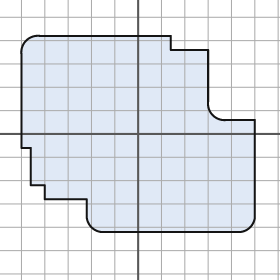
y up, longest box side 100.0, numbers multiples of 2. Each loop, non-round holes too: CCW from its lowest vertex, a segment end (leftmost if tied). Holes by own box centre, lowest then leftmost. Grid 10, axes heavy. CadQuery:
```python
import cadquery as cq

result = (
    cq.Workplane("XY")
    .moveTo(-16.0, -42.0)
    .lineTo(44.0, -42.0)
    .threePointArc((48.0, -40.0), (50.0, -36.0))
    .lineTo(50.0, 6.0)
    .lineTo(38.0, 6.0)
    .threePointArc((32.0, 8.0), (30.0, 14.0))
    .lineTo(30.0, 36.0)
    .lineTo(14.0, 36.0)
    .lineTo(14.0, 42.0)
    .lineTo(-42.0, 42.0)
    .threePointArc((-48.0, 40.0), (-50.0, 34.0))
    .lineTo(-50.0, -6.0)
    .lineTo(-46.0, -6.0)
    .lineTo(-46.0, -22.0)
    .lineTo(-40.0, -22.0)
    .lineTo(-40.0, -28.0)
    .lineTo(-22.0, -28.0)
    .lineTo(-22.0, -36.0)
    .threePointArc((-20.0, -40.0), (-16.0, -42.0))
    .close()
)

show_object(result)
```